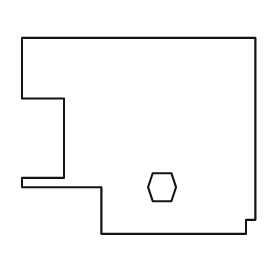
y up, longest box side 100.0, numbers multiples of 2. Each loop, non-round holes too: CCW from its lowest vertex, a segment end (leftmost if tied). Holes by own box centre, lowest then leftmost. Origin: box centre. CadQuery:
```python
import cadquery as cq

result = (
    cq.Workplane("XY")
    .moveTo(-16.0, -42.0)
    .lineTo(46.0, -42.0)
    .lineTo(46.0, -36.0)
    .lineTo(50.0, -36.0)
    .lineTo(50.0, 42.0)
    .lineTo(-50.0, 42.0)
    .lineTo(-50.0, 16.0)
    .lineTo(-32.0, 16.0)
    .lineTo(-32.0, -18.0)
    .lineTo(-50.0, -18.0)
    .lineTo(-50.0, -22.0)
    .lineTo(-16.0, -22.0)
    .close()
    .moveTo(6.0, -28.0)
    .lineTo(14.0, -28.0)
    .lineTo(16.0, -22.0)
    .lineTo(14.0, -16.0)
    .lineTo(6.0, -16.0)
    .lineTo(4.0, -22.0)
    .close()
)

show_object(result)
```